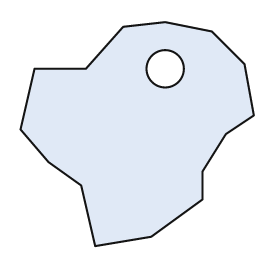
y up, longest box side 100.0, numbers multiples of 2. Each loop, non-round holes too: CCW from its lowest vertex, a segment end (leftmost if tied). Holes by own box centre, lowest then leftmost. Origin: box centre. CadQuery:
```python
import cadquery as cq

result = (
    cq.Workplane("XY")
    .moveTo(-18.0, -48.0)
    .lineTo(6.0, -44.0)
    .lineTo(28.0, -28.0)
    .lineTo(28.0, -16.0)
    .lineTo(38.0, 0.0)
    .lineTo(50.0, 8.0)
    .lineTo(46.0, 30.0)
    .lineTo(32.0, 44.0)
    .lineTo(12.0, 48.0)
    .lineTo(-6.0, 46.0)
    .lineTo(-22.0, 28.0)
    .lineTo(-44.0, 28.0)
    .lineTo(-50.0, 2.0)
    .lineTo(-38.0, -12.0)
    .lineTo(-24.0, -22.0)
    .close()
    .moveTo(12.0, 28.0)
    .circle(8.0)
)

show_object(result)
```